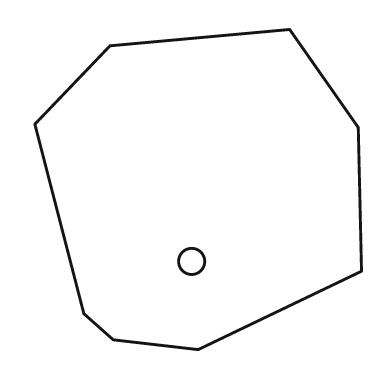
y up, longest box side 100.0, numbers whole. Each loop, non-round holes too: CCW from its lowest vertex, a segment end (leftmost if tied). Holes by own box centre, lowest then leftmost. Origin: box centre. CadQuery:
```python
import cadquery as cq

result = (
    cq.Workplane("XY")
    .moveTo(0.0, -49.0)
    .lineTo(50.0, -25.0)
    .lineTo(49.0, 19.0)
    .lineTo(28.0, 49.0)
    .lineTo(-27.0, 44.0)
    .lineTo(-50.0, 20.0)
    .lineTo(-35.0, -38.0)
    .lineTo(-26.0, -46.0)
    .close()
    .moveTo(-2.0, -22.0)
    .circle(4.0)
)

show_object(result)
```